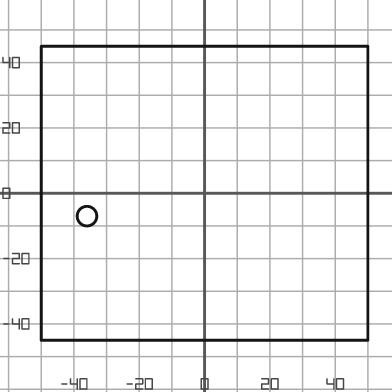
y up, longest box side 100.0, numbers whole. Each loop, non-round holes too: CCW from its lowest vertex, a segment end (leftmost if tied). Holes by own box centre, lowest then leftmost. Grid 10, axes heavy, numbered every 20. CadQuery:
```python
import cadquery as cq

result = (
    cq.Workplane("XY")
    .moveTo(-50.0, -45.0)
    .lineTo(50.0, -45.0)
    .lineTo(50.0, 45.0)
    .lineTo(-50.0, 45.0)
    .close()
    .moveTo(-36.0, -7.0)
    .circle(3.0)
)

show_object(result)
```